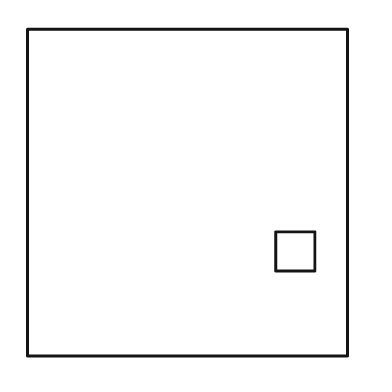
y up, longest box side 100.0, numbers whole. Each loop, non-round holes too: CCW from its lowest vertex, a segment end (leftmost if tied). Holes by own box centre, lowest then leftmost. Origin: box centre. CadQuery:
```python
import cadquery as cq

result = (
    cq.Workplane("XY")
    .moveTo(-49.0, -50.0)
    .lineTo(49.0, -50.0)
    .lineTo(49.0, 50.0)
    .lineTo(-49.0, 50.0)
    .close()
    .moveTo(27.0, -24.0)
    .lineTo(39.0, -24.0)
    .lineTo(39.0, -12.0)
    .lineTo(27.0, -12.0)
    .close()
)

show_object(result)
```